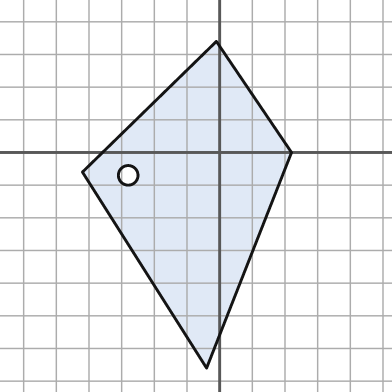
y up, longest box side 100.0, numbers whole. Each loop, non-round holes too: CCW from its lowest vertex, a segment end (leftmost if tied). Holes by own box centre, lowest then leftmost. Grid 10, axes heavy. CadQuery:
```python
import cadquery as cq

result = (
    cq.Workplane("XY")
    .moveTo(-4.0, -66.0)
    .lineTo(22.0, 0.0)
    .lineTo(-1.0, 34.0)
    .lineTo(-42.0, -6.0)
    .close()
    .moveTo(-28.0, -7.0)
    .circle(3.0)
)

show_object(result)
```